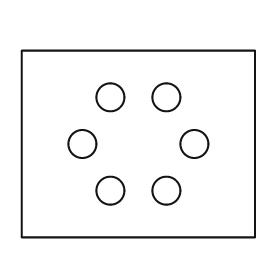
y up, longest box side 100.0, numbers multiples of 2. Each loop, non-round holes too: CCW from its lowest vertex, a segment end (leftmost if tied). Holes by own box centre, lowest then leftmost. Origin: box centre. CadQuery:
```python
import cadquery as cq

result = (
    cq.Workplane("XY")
    .moveTo(-50.0, -40.0)
    .lineTo(50.0, -40.0)
    .lineTo(50.0, 40.0)
    .lineTo(-50.0, 40.0)
    .close()
    .moveTo(-12.0, -20.0)
    .circle(6.0)
    .moveTo(12.0, -20.0)
    .circle(6.0)
    .moveTo(-24.0, 0.0)
    .circle(6.0)
    .moveTo(24.0, 0.0)
    .circle(6.0)
    .moveTo(-12.0, 20.0)
    .circle(6.0)
    .moveTo(12.0, 20.0)
    .circle(6.0)
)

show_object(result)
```